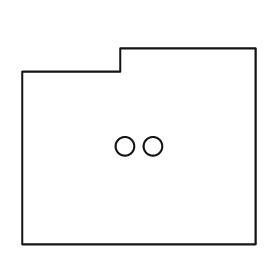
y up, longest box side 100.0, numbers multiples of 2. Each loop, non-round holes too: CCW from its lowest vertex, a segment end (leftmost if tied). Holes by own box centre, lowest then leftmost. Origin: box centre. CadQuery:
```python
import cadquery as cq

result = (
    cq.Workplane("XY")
    .moveTo(-50.0, -42.0)
    .lineTo(50.0, -42.0)
    .lineTo(50.0, 42.0)
    .lineTo(-8.0, 42.0)
    .lineTo(-8.0, 32.0)
    .lineTo(-50.0, 32.0)
    .close()
    .moveTo(-6.0, 0.0)
    .circle(4.0)
    .moveTo(6.0, 0.0)
    .circle(4.0)
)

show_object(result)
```